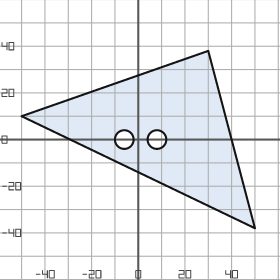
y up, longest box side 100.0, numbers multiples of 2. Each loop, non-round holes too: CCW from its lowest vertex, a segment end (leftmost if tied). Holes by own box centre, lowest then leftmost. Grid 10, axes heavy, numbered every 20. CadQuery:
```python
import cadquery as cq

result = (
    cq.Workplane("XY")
    .moveTo(50.0, -38.0)
    .lineTo(30.0, 38.0)
    .lineTo(-50.0, 10.0)
    .close()
    .moveTo(-6.0, 0.0)
    .circle(4.0)
    .moveTo(8.0, 0.0)
    .circle(4.0)
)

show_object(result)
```